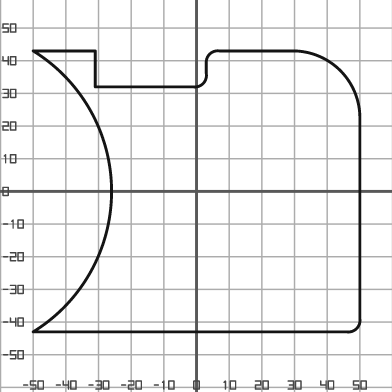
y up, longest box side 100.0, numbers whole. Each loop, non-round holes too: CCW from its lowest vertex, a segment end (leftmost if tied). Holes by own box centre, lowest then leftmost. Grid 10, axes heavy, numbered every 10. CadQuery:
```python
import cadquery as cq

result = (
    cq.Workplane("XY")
    .moveTo(-50.0, -43.0)
    .lineTo(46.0, -43.0)
    .threePointArc((49.0, -42.0), (50.0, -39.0))
    .lineTo(50.0, 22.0)
    .threePointArc((44.0, 37.0), (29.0, 43.0))
    .lineTo(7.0, 43.0)
    .threePointArc((4.0, 42.0), (3.0, 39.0))
    .lineTo(3.0, 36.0)
    .threePointArc((2.0, 33.0), (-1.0, 32.0))
    .lineTo(-31.0, 32.0)
    .lineTo(-31.0, 43.0)
    .lineTo(-50.0, 43.0)
    .threePointArc((-26.0, 0.0), (-50.0, -43.0))
    .close()
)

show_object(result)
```